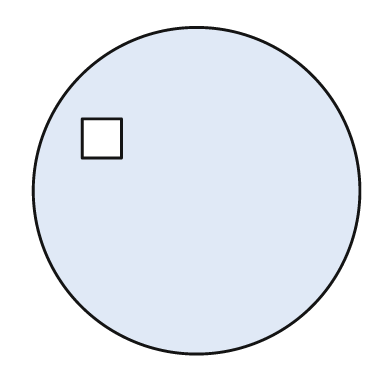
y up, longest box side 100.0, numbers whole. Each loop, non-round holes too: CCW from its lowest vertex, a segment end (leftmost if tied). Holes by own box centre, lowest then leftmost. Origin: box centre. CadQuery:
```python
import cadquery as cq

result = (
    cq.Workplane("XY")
    .moveTo(0.0, 0.0)
    .circle(50.0)
    .moveTo(-35.0, 10.0)
    .lineTo(-23.0, 10.0)
    .lineTo(-23.0, 22.0)
    .lineTo(-35.0, 22.0)
    .close()
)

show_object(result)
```